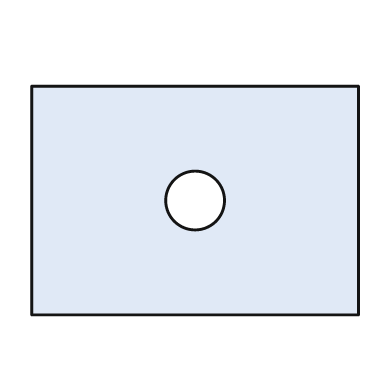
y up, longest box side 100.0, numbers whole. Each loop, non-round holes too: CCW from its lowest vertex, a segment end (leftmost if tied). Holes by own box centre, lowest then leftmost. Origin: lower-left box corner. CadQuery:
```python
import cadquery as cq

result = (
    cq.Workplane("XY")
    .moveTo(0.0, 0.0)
    .lineTo(100.0, 0.0)
    .lineTo(100.0, 70.0)
    .lineTo(0.0, 70.0)
    .close()
    .moveTo(50.0, 35.0)
    .circle(9.0)
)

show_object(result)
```